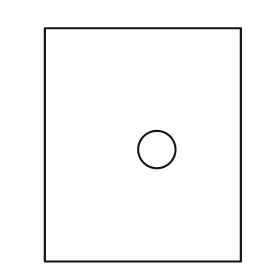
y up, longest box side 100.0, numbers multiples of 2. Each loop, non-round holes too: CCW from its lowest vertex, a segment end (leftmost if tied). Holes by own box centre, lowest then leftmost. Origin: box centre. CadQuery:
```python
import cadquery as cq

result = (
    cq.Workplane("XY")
    .moveTo(-42.0, -50.0)
    .lineTo(42.0, -50.0)
    .lineTo(42.0, 50.0)
    .lineTo(-42.0, 50.0)
    .close()
    .moveTo(6.0, -2.0)
    .circle(8.0)
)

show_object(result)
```